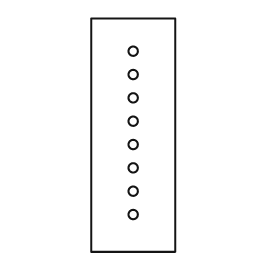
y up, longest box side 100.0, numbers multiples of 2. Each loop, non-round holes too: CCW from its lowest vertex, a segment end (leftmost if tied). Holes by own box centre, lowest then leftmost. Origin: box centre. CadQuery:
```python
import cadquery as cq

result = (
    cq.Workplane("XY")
    .moveTo(-18.0, -50.0)
    .lineTo(18.0, -50.0)
    .lineTo(18.0, 50.0)
    .lineTo(-18.0, 50.0)
    .close()
    .moveTo(0.0, -34.0)
    .circle(2.0)
    .moveTo(0.0, -24.0)
    .circle(2.0)
    .moveTo(0.0, -14.0)
    .circle(2.0)
    .moveTo(0.0, -4.0)
    .circle(2.0)
    .moveTo(0.0, 6.0)
    .circle(2.0)
    .moveTo(0.0, 16.0)
    .circle(2.0)
    .moveTo(0.0, 26.0)
    .circle(2.0)
    .moveTo(0.0, 36.0)
    .circle(2.0)
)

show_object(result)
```